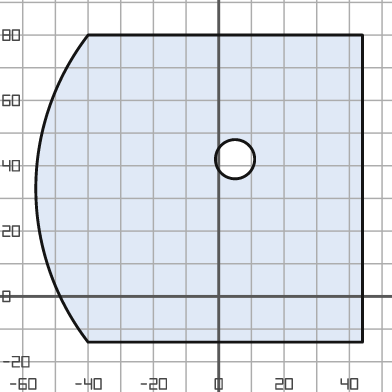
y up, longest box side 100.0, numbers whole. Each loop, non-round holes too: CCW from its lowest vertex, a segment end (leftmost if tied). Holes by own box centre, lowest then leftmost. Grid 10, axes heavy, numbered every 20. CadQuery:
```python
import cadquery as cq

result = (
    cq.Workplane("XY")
    .moveTo(-40.0, -14.0)
    .lineTo(44.0, -14.0)
    .lineTo(44.0, 80.0)
    .lineTo(-40.0, 80.0)
    .threePointArc((-56.0, 33.0), (-40.0, -14.0))
    .close()
    .moveTo(5.0, 42.0)
    .circle(6.0)
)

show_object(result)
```